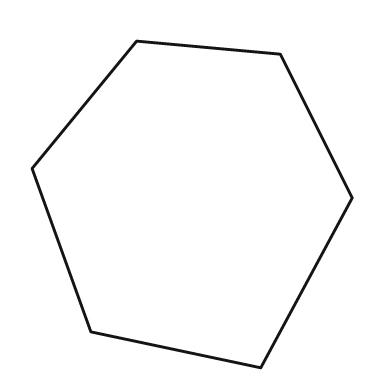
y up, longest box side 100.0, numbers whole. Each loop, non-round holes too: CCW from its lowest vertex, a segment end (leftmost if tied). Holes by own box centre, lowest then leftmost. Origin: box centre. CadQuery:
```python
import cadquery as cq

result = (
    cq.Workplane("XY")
    .moveTo(21.0, -50.0)
    .lineTo(49.0, 2.0)
    .lineTo(27.0, 46.0)
    .lineTo(-17.0, 50.0)
    .lineTo(-49.0, 11.0)
    .lineTo(-31.0, -39.0)
    .close()
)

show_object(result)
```